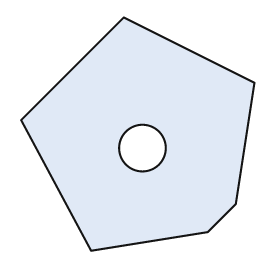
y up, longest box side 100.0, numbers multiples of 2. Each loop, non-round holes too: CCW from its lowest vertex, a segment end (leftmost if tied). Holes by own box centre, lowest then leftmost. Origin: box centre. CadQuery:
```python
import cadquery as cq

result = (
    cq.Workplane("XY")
    .moveTo(-20.0, -50.0)
    .lineTo(30.0, -42.0)
    .lineTo(42.0, -30.0)
    .lineTo(50.0, 22.0)
    .lineTo(-6.0, 50.0)
    .lineTo(-50.0, 6.0)
    .close()
    .moveTo(2.0, -6.0)
    .circle(10.0)
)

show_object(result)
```